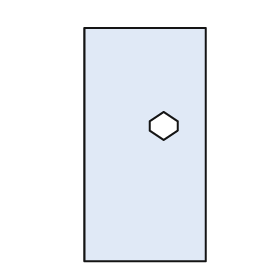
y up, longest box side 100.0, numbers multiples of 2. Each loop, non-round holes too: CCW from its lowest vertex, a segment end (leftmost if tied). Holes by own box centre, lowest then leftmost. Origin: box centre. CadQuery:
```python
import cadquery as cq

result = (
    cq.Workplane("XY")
    .moveTo(-26.0, -50.0)
    .lineTo(26.0, -50.0)
    .lineTo(26.0, 50.0)
    .lineTo(-26.0, 50.0)
    .close()
    .moveTo(8.0, 2.0)
    .lineTo(14.0, 6.0)
    .lineTo(14.0, 10.0)
    .lineTo(8.0, 14.0)
    .lineTo(2.0, 10.0)
    .lineTo(2.0, 6.0)
    .close()
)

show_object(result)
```